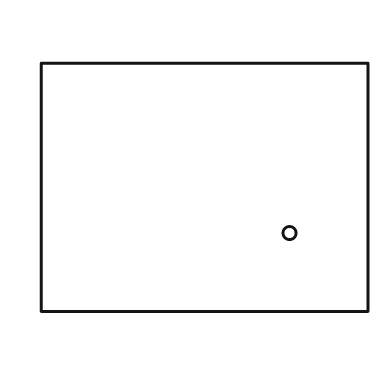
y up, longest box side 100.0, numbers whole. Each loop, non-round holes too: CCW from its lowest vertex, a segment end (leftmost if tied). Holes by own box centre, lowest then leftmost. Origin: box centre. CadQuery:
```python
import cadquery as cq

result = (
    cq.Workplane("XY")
    .moveTo(-50.0, -38.0)
    .lineTo(50.0, -38.0)
    .lineTo(50.0, 38.0)
    .lineTo(-50.0, 38.0)
    .close()
    .moveTo(26.0, -14.0)
    .circle(2.0)
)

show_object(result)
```